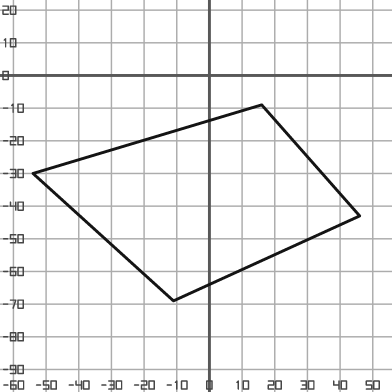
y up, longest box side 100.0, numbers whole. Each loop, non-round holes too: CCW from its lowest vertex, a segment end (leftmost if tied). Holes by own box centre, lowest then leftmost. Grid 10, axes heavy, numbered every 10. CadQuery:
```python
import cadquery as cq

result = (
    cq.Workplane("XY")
    .moveTo(-11.0, -69.0)
    .lineTo(46.0, -43.0)
    .lineTo(16.0, -9.0)
    .lineTo(-54.0, -30.0)
    .close()
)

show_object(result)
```